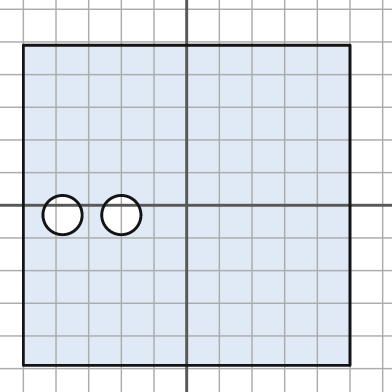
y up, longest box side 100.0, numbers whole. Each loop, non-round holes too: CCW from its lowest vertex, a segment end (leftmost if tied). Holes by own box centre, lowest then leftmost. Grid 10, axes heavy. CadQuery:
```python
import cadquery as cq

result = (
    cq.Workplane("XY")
    .moveTo(-50.0, -49.0)
    .lineTo(50.0, -49.0)
    .lineTo(50.0, 49.0)
    .lineTo(-50.0, 49.0)
    .close()
    .moveTo(-38.0, -3.0)
    .circle(6.0)
    .moveTo(-20.0, -3.0)
    .circle(6.0)
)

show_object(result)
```